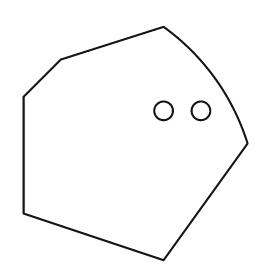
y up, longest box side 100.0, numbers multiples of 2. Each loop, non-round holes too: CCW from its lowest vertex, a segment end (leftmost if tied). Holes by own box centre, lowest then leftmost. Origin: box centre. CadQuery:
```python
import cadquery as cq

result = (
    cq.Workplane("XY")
    .moveTo(12.0, -50.0)
    .lineTo(48.0, 0.0)
    .threePointArc((34.0, 28.0), (12.0, 50.0))
    .lineTo(-32.0, 36.0)
    .lineTo(-48.0, 20.0)
    .lineTo(-48.0, -30.0)
    .close()
    .moveTo(12.0, 14.0)
    .circle(4.0)
    .moveTo(28.0, 14.0)
    .circle(4.0)
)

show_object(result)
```